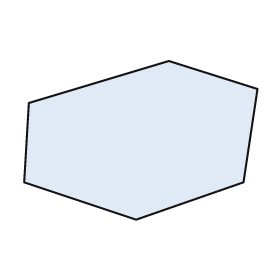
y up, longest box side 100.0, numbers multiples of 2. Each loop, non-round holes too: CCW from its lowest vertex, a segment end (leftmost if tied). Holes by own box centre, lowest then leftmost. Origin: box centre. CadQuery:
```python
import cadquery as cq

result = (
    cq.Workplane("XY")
    .moveTo(-2.0, -34.0)
    .lineTo(44.0, -18.0)
    .lineTo(50.0, 22.0)
    .lineTo(12.0, 34.0)
    .lineTo(-48.0, 16.0)
    .lineTo(-50.0, -18.0)
    .close()
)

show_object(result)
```